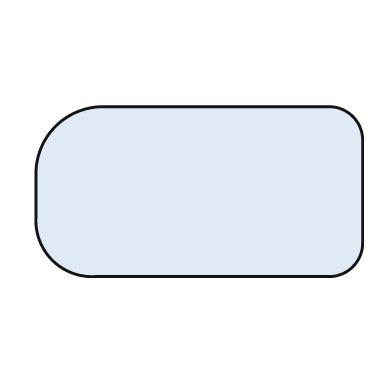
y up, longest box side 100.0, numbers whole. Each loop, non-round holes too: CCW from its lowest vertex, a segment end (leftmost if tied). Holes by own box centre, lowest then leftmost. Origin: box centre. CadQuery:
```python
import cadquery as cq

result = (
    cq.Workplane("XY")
    .moveTo(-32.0, -26.0)
    .lineTo(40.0, -26.0)
    .threePointArc((47.0, -23.0), (50.0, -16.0))
    .lineTo(50.0, 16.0)
    .threePointArc((47.0, 23.0), (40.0, 26.0))
    .lineTo(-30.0, 26.0)
    .threePointArc((-44.0, 20.0), (-50.0, 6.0))
    .lineTo(-50.0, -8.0)
    .threePointArc((-45.0, -21.0), (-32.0, -26.0))
    .close()
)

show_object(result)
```